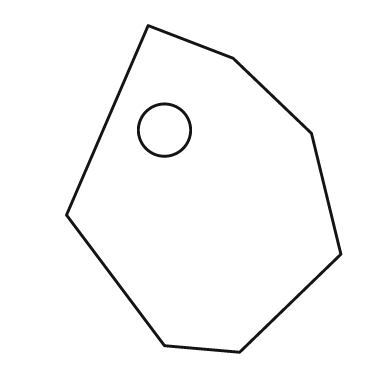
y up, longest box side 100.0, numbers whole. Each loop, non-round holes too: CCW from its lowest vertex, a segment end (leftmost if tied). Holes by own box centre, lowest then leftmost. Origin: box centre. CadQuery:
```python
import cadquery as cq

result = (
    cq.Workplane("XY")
    .moveTo(11.0, -50.0)
    .lineTo(42.0, -20.0)
    .lineTo(33.0, 17.0)
    .lineTo(9.0, 40.0)
    .lineTo(-17.0, 50.0)
    .lineTo(-42.0, -8.0)
    .lineTo(-12.0, -48.0)
    .close()
    .moveTo(-12.0, 18.0)
    .circle(8.0)
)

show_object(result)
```